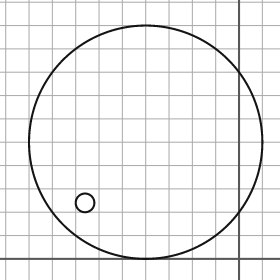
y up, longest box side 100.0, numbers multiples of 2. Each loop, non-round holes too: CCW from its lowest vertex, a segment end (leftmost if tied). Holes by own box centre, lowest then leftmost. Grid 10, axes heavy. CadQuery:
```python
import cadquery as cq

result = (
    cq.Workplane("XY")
    .moveTo(-40.0, 50.0)
    .circle(50.0)
    .moveTo(-66.0, 24.0)
    .circle(4.0)
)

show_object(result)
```